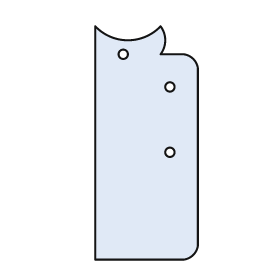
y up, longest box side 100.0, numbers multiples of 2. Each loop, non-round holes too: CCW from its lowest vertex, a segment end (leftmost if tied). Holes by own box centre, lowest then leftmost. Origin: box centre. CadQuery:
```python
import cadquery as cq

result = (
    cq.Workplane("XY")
    .moveTo(-22.0, -50.0)
    .lineTo(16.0, -50.0)
    .threePointArc((20.0, -48.0), (22.0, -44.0))
    .lineTo(22.0, 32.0)
    .threePointArc((20.0, 36.0), (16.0, 38.0))
    .lineTo(6.0, 38.0)
    .threePointArc((8.0, 44.0), (6.0, 50.0))
    .threePointArc((-8.0, 44.0), (-22.0, 50.0))
    .close()
    .moveTo(10.0, -4.0)
    .circle(2.0)
    .moveTo(10.0, 24.0)
    .circle(2.0)
    .moveTo(-10.0, 38.0)
    .circle(2.0)
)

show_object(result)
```